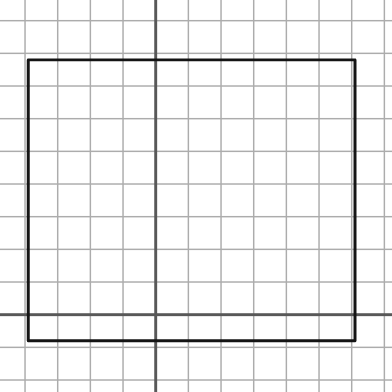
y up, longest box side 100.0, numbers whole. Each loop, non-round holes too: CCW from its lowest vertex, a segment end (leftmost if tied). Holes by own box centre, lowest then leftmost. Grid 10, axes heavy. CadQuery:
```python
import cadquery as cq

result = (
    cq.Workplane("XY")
    .moveTo(-39.0, -8.0)
    .lineTo(61.0, -8.0)
    .lineTo(61.0, 78.0)
    .lineTo(-39.0, 78.0)
    .close()
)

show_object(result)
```